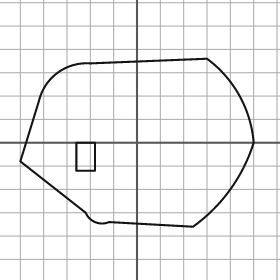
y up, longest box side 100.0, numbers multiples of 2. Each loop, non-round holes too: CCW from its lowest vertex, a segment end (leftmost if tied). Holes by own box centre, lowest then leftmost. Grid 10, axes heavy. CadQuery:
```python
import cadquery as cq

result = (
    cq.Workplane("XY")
    .moveTo(24.0, -36.0)
    .threePointArc((40.0, -20.0), (50.0, 0.0))
    .threePointArc((44.0, 20.0), (30.0, 36.0))
    .lineTo(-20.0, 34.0)
    .threePointArc((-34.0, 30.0), (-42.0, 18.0))
    .lineTo(-50.0, -8.0)
    .lineTo(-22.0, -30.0)
    .threePointArc((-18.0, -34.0), (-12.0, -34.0))
    .close()
    .moveTo(-26.0, -12.0)
    .lineTo(-18.0, -12.0)
    .lineTo(-18.0, 0.0)
    .lineTo(-26.0, 0.0)
    .close()
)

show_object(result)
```